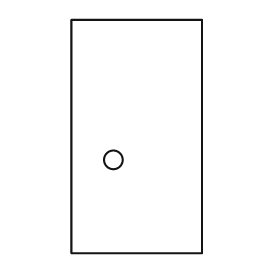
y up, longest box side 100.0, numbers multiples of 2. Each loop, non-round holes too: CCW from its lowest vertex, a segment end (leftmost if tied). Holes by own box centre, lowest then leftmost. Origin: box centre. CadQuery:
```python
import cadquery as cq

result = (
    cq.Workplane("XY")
    .moveTo(-28.0, -50.0)
    .lineTo(28.0, -50.0)
    .lineTo(28.0, 50.0)
    .lineTo(-28.0, 50.0)
    .close()
    .moveTo(-10.0, -10.0)
    .circle(4.0)
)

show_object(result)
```